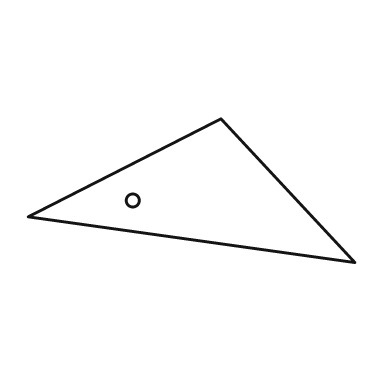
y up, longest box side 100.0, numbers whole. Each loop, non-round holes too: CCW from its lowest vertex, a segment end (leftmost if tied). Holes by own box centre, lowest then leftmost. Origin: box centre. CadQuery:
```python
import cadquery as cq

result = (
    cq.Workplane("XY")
    .moveTo(50.0, -22.0)
    .lineTo(9.0, 22.0)
    .lineTo(-50.0, -8.0)
    .close()
    .moveTo(-18.0, -3.0)
    .circle(2.0)
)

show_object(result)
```